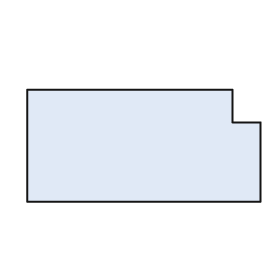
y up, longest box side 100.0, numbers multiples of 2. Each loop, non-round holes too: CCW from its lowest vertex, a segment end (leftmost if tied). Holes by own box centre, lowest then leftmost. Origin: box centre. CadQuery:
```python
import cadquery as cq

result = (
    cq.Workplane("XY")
    .moveTo(-50.0, -24.0)
    .lineTo(50.0, -24.0)
    .lineTo(50.0, 10.0)
    .lineTo(38.0, 10.0)
    .lineTo(38.0, 24.0)
    .lineTo(-50.0, 24.0)
    .close()
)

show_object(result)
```